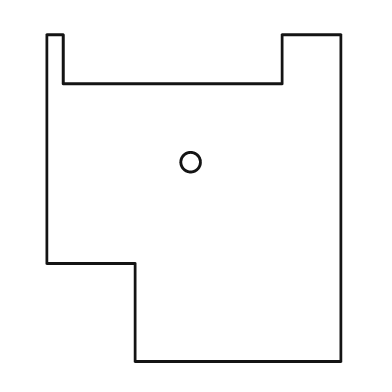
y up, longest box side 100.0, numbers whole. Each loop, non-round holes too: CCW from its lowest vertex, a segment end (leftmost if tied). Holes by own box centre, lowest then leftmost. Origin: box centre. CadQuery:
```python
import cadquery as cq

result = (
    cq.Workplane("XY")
    .moveTo(-18.0, -50.0)
    .lineTo(45.0, -50.0)
    .lineTo(45.0, 50.0)
    .lineTo(27.0, 50.0)
    .lineTo(27.0, 35.0)
    .lineTo(-40.0, 35.0)
    .lineTo(-40.0, 50.0)
    .lineTo(-45.0, 50.0)
    .lineTo(-45.0, -20.0)
    .lineTo(-18.0, -20.0)
    .close()
    .moveTo(-1.0, 11.0)
    .circle(3.0)
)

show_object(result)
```